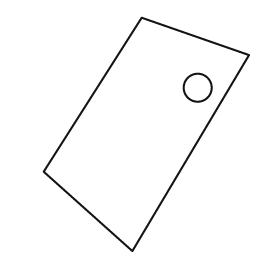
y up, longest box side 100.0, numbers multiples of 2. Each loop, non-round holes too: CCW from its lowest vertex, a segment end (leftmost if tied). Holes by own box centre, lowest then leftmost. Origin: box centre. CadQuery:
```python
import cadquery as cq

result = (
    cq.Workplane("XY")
    .moveTo(-6.0, -50.0)
    .lineTo(44.0, 34.0)
    .lineTo(-2.0, 50.0)
    .lineTo(-44.0, -16.0)
    .close()
    .moveTo(22.0, 20.0)
    .circle(6.0)
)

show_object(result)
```